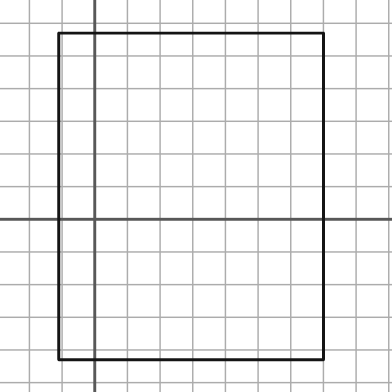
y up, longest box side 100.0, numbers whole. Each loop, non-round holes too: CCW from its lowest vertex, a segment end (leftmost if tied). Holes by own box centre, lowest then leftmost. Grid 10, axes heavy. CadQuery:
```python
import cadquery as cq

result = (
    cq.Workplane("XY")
    .moveTo(-11.0, -43.0)
    .lineTo(70.0, -43.0)
    .lineTo(70.0, 57.0)
    .lineTo(-11.0, 57.0)
    .close()
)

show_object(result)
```